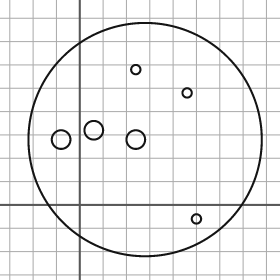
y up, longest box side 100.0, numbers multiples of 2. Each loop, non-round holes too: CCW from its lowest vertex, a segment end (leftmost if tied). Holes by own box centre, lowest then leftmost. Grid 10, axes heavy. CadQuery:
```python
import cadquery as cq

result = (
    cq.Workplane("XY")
    .moveTo(28.0, 28.0)
    .circle(50.0)
    .moveTo(50.0, -6.0)
    .circle(2.0)
    .moveTo(-8.0, 28.0)
    .circle(4.0)
    .moveTo(24.0, 28.0)
    .circle(4.0)
    .moveTo(6.0, 32.0)
    .circle(4.0)
    .moveTo(46.0, 48.0)
    .circle(2.0)
    .moveTo(24.0, 58.0)
    .circle(2.0)
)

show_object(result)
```